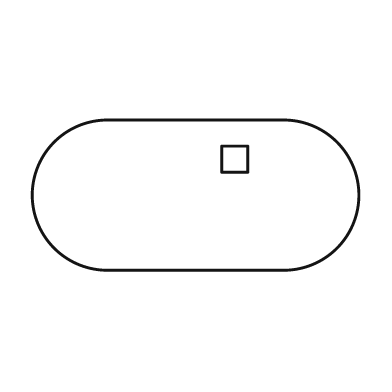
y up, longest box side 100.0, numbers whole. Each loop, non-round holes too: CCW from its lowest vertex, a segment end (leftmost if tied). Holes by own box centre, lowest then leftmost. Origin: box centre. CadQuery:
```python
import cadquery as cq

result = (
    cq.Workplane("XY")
    .moveTo(-27.0, -23.0)
    .lineTo(27.0, -23.0)
    .threePointArc((50.0, 0.0), (27.0, 23.0))
    .lineTo(-27.0, 23.0)
    .threePointArc((-50.0, 0.0), (-27.0, -23.0))
    .close()
    .moveTo(8.0, 7.0)
    .lineTo(16.0, 7.0)
    .lineTo(16.0, 15.0)
    .lineTo(8.0, 15.0)
    .close()
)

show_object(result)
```